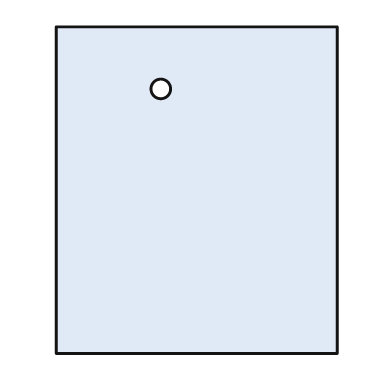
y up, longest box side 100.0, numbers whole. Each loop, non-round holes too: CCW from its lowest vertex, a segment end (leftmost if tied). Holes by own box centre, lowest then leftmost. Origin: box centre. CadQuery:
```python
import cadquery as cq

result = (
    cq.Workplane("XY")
    .moveTo(-43.0, -50.0)
    .lineTo(43.0, -50.0)
    .lineTo(43.0, 50.0)
    .lineTo(-43.0, 50.0)
    .close()
    .moveTo(-11.0, 31.0)
    .circle(3.0)
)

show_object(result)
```